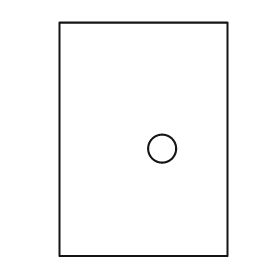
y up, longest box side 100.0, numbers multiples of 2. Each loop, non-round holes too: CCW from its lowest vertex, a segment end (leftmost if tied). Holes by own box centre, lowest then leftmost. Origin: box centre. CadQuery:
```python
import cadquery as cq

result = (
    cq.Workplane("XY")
    .moveTo(-36.0, -50.0)
    .lineTo(36.0, -50.0)
    .lineTo(36.0, 50.0)
    .lineTo(-36.0, 50.0)
    .close()
    .moveTo(8.0, -4.0)
    .circle(6.0)
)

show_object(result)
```